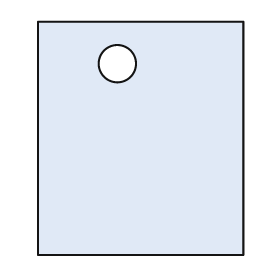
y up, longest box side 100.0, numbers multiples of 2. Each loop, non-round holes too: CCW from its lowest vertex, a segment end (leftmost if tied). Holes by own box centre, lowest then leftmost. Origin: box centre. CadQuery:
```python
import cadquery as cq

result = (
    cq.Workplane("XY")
    .moveTo(-44.0, -50.0)
    .lineTo(44.0, -50.0)
    .lineTo(44.0, 50.0)
    .lineTo(-44.0, 50.0)
    .close()
    .moveTo(-10.0, 32.0)
    .circle(8.0)
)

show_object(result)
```